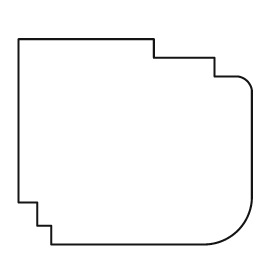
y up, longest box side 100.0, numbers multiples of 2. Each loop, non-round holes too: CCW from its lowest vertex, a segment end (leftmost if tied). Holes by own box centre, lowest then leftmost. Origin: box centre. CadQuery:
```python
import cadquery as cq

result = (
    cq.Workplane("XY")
    .moveTo(-36.0, -44.0)
    .lineTo(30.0, -44.0)
    .threePointArc((44.0, -38.0), (50.0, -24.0))
    .lineTo(50.0, 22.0)
    .threePointArc((48.0, 26.0), (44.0, 28.0))
    .lineTo(34.0, 28.0)
    .lineTo(34.0, 36.0)
    .lineTo(8.0, 36.0)
    .lineTo(8.0, 44.0)
    .lineTo(-50.0, 44.0)
    .lineTo(-50.0, -26.0)
    .lineTo(-42.0, -26.0)
    .lineTo(-42.0, -36.0)
    .lineTo(-36.0, -36.0)
    .close()
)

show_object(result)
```